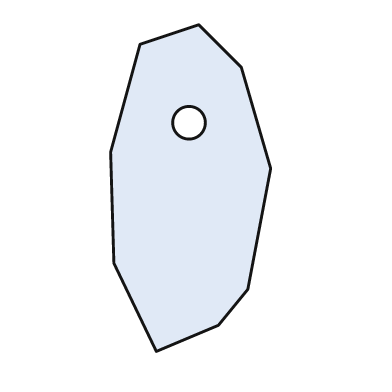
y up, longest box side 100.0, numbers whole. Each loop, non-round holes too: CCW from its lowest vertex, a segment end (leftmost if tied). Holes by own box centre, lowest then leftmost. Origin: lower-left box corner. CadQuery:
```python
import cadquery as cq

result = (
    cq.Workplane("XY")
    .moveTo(14.0, 0.0)
    .lineTo(33.0, 8.0)
    .lineTo(42.0, 19.0)
    .lineTo(49.0, 56.0)
    .lineTo(40.0, 87.0)
    .lineTo(27.0, 100.0)
    .lineTo(9.0, 94.0)
    .lineTo(0.0, 61.0)
    .lineTo(1.0, 27.0)
    .close()
    .moveTo(24.0, 70.0)
    .circle(5.0)
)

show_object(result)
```